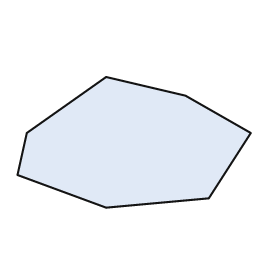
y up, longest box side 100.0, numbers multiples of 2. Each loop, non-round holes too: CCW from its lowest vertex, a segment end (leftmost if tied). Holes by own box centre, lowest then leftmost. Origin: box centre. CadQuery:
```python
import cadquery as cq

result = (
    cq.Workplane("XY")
    .moveTo(-12.0, -28.0)
    .lineTo(32.0, -24.0)
    .lineTo(50.0, 4.0)
    .lineTo(22.0, 20.0)
    .lineTo(-12.0, 28.0)
    .lineTo(-46.0, 4.0)
    .lineTo(-50.0, -14.0)
    .close()
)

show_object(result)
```